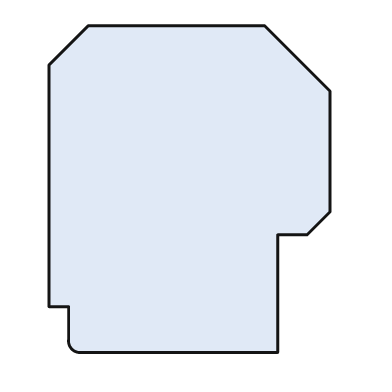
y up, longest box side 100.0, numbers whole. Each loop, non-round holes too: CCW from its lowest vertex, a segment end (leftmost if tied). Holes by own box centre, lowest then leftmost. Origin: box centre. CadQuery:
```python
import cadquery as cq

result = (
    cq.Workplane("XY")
    .moveTo(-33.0, -50.0)
    .lineTo(27.0, -50.0)
    .lineTo(27.0, -14.0)
    .lineTo(36.0, -14.0)
    .lineTo(43.0, -7.0)
    .lineTo(43.0, 30.0)
    .lineTo(23.0, 50.0)
    .lineTo(-31.0, 50.0)
    .lineTo(-43.0, 38.0)
    .lineTo(-43.0, -36.0)
    .lineTo(-37.0, -36.0)
    .lineTo(-37.0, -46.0)
    .threePointArc((-36.0, -49.0), (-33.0, -50.0))
    .close()
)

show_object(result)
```